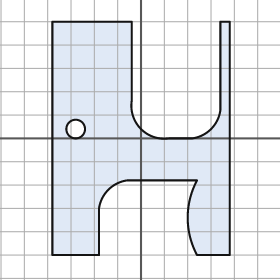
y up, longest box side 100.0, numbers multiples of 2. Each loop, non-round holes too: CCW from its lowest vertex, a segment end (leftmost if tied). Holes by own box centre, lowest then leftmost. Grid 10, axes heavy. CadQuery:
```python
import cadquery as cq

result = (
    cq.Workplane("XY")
    .moveTo(-38.0, -50.0)
    .lineTo(-18.0, -50.0)
    .lineTo(-18.0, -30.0)
    .threePointArc((-14.0, -22.0), (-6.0, -18.0))
    .lineTo(24.0, -18.0)
    .threePointArc((20.0, -34.0), (24.0, -50.0))
    .lineTo(38.0, -50.0)
    .lineTo(38.0, 50.0)
    .lineTo(34.0, 50.0)
    .lineTo(34.0, 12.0)
    .threePointArc((30.0, 4.0), (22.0, 0.0))
    .lineTo(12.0, 0.0)
    .threePointArc((0.0, 4.0), (-4.0, 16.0))
    .lineTo(-4.0, 50.0)
    .lineTo(-38.0, 50.0)
    .close()
    .moveTo(-28.0, 4.0)
    .circle(4.0)
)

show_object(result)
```